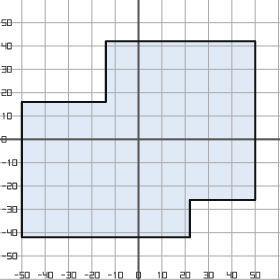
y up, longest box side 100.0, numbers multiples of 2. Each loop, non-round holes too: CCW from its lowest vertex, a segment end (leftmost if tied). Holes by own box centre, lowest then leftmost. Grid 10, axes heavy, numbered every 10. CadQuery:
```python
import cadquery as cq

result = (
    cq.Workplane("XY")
    .moveTo(-50.0, -42.0)
    .lineTo(22.0, -42.0)
    .lineTo(22.0, -26.0)
    .lineTo(50.0, -26.0)
    .lineTo(50.0, 42.0)
    .lineTo(-14.0, 42.0)
    .lineTo(-14.0, 16.0)
    .lineTo(-50.0, 16.0)
    .close()
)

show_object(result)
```